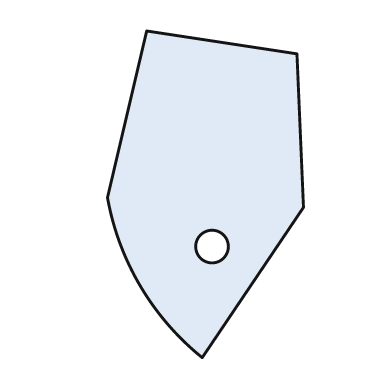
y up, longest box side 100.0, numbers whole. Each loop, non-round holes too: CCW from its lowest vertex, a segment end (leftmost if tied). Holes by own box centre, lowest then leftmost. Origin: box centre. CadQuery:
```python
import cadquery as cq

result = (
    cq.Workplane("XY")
    .moveTo(-1.0, -50.0)
    .lineTo(30.0, -4.0)
    .lineTo(28.0, 43.0)
    .lineTo(-18.0, 50.0)
    .lineTo(-30.0, -1.0)
    .threePointArc((-20.0, -28.0), (-1.0, -50.0))
    .close()
    .moveTo(2.0, -16.0)
    .circle(5.0)
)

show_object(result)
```